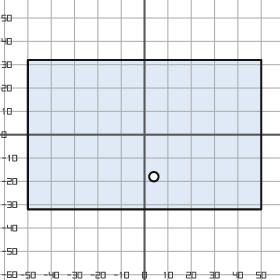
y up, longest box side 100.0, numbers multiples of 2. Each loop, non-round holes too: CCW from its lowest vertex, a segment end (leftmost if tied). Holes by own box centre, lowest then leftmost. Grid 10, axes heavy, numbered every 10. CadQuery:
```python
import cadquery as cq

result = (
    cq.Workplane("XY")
    .moveTo(-50.0, -32.0)
    .lineTo(50.0, -32.0)
    .lineTo(50.0, 32.0)
    .lineTo(-50.0, 32.0)
    .close()
    .moveTo(4.0, -18.0)
    .circle(2.0)
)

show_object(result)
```